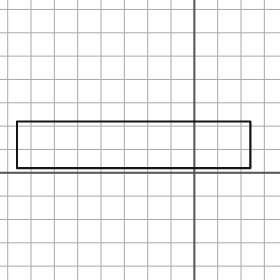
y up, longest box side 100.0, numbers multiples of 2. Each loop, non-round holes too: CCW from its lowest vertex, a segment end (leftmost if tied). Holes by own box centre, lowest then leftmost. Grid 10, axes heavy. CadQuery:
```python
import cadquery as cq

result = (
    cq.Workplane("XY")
    .moveTo(-76.0, 2.0)
    .lineTo(24.0, 2.0)
    .lineTo(24.0, 22.0)
    .lineTo(-76.0, 22.0)
    .close()
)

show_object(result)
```